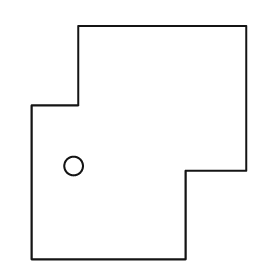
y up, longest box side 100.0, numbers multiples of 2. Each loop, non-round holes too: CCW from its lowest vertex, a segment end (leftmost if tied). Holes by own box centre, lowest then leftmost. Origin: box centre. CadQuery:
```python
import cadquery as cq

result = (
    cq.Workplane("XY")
    .moveTo(-46.0, -50.0)
    .lineTo(20.0, -50.0)
    .lineTo(20.0, -12.0)
    .lineTo(46.0, -12.0)
    .lineTo(46.0, 50.0)
    .lineTo(-26.0, 50.0)
    .lineTo(-26.0, 16.0)
    .lineTo(-46.0, 16.0)
    .close()
    .moveTo(-28.0, -10.0)
    .circle(4.0)
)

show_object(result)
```